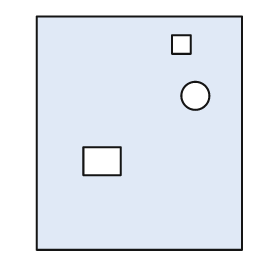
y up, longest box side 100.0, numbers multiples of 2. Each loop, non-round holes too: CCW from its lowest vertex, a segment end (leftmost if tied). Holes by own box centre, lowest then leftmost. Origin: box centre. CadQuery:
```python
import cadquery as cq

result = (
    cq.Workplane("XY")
    .moveTo(-44.0, -50.0)
    .lineTo(44.0, -50.0)
    .lineTo(44.0, 50.0)
    .lineTo(-44.0, 50.0)
    .close()
    .moveTo(-24.0, -18.0)
    .lineTo(-8.0, -18.0)
    .lineTo(-8.0, -6.0)
    .lineTo(-24.0, -6.0)
    .close()
    .moveTo(24.0, 16.0)
    .circle(6.0)
    .moveTo(14.0, 34.0)
    .lineTo(22.0, 34.0)
    .lineTo(22.0, 42.0)
    .lineTo(14.0, 42.0)
    .close()
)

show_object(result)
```